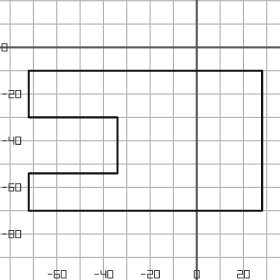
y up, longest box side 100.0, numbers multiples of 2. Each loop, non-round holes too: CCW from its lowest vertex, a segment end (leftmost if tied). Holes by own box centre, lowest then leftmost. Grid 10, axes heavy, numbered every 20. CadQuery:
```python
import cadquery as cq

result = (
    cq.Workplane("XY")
    .moveTo(-72.0, -70.0)
    .lineTo(28.0, -70.0)
    .lineTo(28.0, -10.0)
    .lineTo(-72.0, -10.0)
    .lineTo(-72.0, -30.0)
    .lineTo(-34.0, -30.0)
    .lineTo(-34.0, -54.0)
    .lineTo(-72.0, -54.0)
    .close()
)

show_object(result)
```